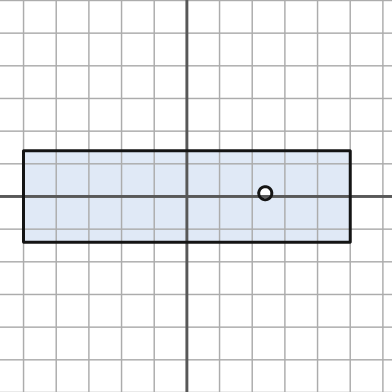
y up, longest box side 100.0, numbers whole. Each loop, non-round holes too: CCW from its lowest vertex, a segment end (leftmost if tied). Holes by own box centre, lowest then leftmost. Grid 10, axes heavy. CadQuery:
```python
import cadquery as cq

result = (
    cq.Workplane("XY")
    .moveTo(-50.0, -14.0)
    .lineTo(50.0, -14.0)
    .lineTo(50.0, 14.0)
    .lineTo(-50.0, 14.0)
    .close()
    .moveTo(24.0, 1.0)
    .circle(2.0)
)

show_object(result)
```